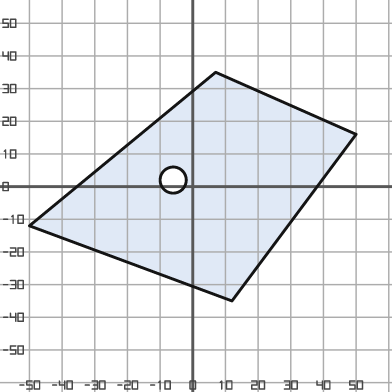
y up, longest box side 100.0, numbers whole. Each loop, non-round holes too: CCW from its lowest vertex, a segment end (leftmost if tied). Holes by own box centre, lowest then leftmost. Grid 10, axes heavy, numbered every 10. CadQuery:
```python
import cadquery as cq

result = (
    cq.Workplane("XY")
    .moveTo(12.0, -35.0)
    .lineTo(50.0, 16.0)
    .lineTo(7.0, 35.0)
    .lineTo(-50.0, -12.0)
    .close()
    .moveTo(-6.0, 2.0)
    .circle(4.0)
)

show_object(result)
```